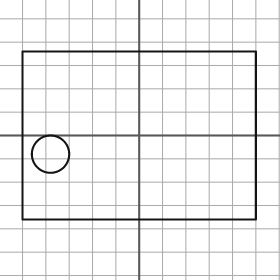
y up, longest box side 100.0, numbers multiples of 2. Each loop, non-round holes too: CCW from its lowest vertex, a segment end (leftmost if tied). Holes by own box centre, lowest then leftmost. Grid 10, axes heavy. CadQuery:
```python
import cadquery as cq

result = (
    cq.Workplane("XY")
    .moveTo(-50.0, -36.0)
    .lineTo(50.0, -36.0)
    .lineTo(50.0, 36.0)
    .lineTo(-50.0, 36.0)
    .close()
    .moveTo(-38.0, -8.0)
    .circle(8.0)
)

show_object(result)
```